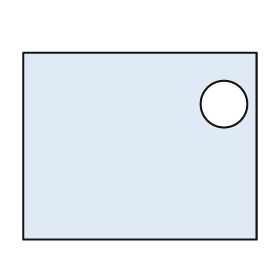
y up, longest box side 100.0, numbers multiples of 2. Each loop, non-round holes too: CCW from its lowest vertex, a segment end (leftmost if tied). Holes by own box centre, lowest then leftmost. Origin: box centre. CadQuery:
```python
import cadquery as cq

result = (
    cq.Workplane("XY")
    .moveTo(-50.0, -40.0)
    .lineTo(50.0, -40.0)
    .lineTo(50.0, 40.0)
    .lineTo(-50.0, 40.0)
    .close()
    .moveTo(36.0, 18.0)
    .circle(10.0)
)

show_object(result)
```